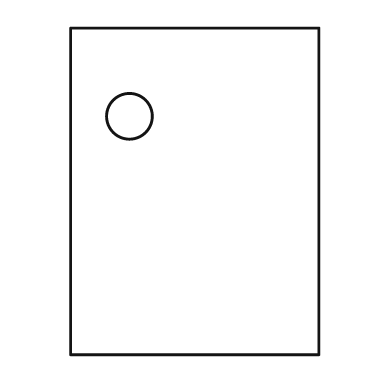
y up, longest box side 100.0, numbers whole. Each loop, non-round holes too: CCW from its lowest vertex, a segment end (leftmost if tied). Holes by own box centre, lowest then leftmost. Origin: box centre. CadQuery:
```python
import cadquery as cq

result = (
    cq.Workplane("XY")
    .moveTo(-38.0, -50.0)
    .lineTo(38.0, -50.0)
    .lineTo(38.0, 50.0)
    .lineTo(-38.0, 50.0)
    .close()
    .moveTo(-20.0, 23.0)
    .circle(7.0)
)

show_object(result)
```